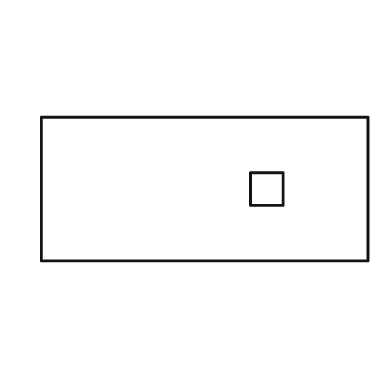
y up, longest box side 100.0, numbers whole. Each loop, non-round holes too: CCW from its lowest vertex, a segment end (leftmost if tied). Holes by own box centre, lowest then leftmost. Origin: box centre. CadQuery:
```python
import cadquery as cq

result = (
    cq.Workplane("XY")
    .moveTo(-50.0, -22.0)
    .lineTo(50.0, -22.0)
    .lineTo(50.0, 22.0)
    .lineTo(-50.0, 22.0)
    .close()
    .moveTo(14.0, -5.0)
    .lineTo(24.0, -5.0)
    .lineTo(24.0, 5.0)
    .lineTo(14.0, 5.0)
    .close()
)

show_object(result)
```